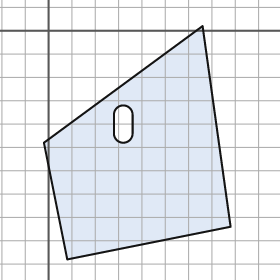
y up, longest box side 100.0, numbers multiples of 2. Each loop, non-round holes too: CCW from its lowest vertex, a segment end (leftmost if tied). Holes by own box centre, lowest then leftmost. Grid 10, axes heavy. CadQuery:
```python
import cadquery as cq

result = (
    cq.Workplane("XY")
    .moveTo(8.0, -98.0)
    .lineTo(78.0, -84.0)
    .lineTo(66.0, 2.0)
    .lineTo(-2.0, -48.0)
    .close()
    .moveTo(28.0, -44.0)
    .threePointArc((32.0, -48.0), (36.0, -44.0))
    .lineTo(36.0, -36.0)
    .threePointArc((32.0, -32.0), (28.0, -36.0))
    .close()
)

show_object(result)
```